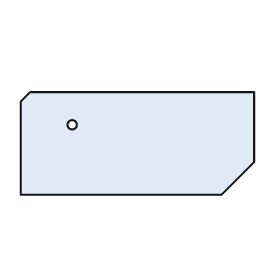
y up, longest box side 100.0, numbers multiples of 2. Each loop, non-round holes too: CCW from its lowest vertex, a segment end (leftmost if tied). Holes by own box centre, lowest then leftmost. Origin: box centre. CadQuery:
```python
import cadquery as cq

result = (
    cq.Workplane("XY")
    .moveTo(-50.0, -22.0)
    .lineTo(36.0, -22.0)
    .lineTo(50.0, -8.0)
    .lineTo(50.0, 22.0)
    .lineTo(-46.0, 22.0)
    .lineTo(-50.0, 18.0)
    .close()
    .moveTo(-28.0, 8.0)
    .circle(2.0)
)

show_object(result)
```